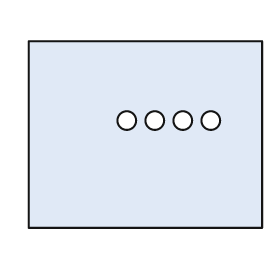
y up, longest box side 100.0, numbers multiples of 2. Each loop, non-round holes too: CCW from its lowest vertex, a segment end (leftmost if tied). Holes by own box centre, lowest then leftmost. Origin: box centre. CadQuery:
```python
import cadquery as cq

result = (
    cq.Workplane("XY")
    .moveTo(-50.0, -40.0)
    .lineTo(50.0, -40.0)
    .lineTo(50.0, 40.0)
    .lineTo(-50.0, 40.0)
    .close()
    .moveTo(-8.0, 6.0)
    .circle(4.0)
    .moveTo(4.0, 6.0)
    .circle(4.0)
    .moveTo(16.0, 6.0)
    .circle(4.0)
    .moveTo(28.0, 6.0)
    .circle(4.0)
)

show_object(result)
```